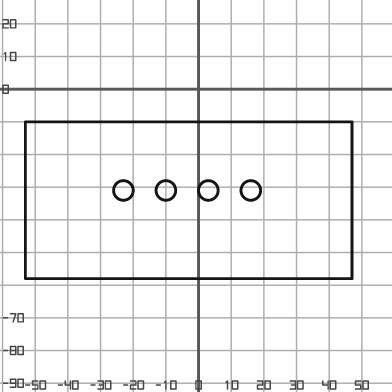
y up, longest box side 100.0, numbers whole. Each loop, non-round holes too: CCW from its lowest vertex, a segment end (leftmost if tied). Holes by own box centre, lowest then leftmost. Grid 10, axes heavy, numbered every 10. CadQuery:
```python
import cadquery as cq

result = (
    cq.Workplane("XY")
    .moveTo(-53.0, -58.0)
    .lineTo(47.0, -58.0)
    .lineTo(47.0, -10.0)
    .lineTo(-53.0, -10.0)
    .close()
    .moveTo(-23.0, -31.0)
    .circle(3.0)
    .moveTo(-10.0, -31.0)
    .circle(3.0)
    .moveTo(3.0, -31.0)
    .circle(3.0)
    .moveTo(16.0, -31.0)
    .circle(3.0)
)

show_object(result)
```